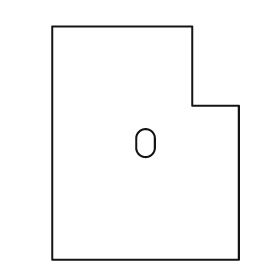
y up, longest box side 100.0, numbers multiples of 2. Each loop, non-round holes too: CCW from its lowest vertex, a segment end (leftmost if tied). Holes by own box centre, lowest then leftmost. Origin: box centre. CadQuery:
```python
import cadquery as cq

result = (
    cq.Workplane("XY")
    .moveTo(-40.0, -50.0)
    .lineTo(40.0, -50.0)
    .lineTo(40.0, 16.0)
    .lineTo(20.0, 16.0)
    .lineTo(20.0, 50.0)
    .lineTo(-40.0, 50.0)
    .close()
    .moveTo(-4.0, -2.0)
    .threePointArc((0.0, -6.0), (4.0, -2.0))
    .lineTo(4.0, 2.0)
    .threePointArc((0.0, 6.0), (-4.0, 2.0))
    .close()
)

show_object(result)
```